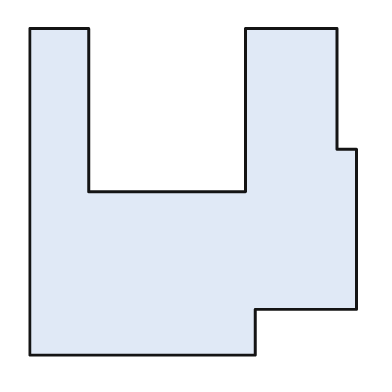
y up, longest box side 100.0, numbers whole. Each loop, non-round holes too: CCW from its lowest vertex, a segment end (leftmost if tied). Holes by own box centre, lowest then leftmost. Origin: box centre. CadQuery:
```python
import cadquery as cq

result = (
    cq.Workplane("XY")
    .moveTo(-50.0, -50.0)
    .lineTo(19.0, -50.0)
    .lineTo(19.0, -36.0)
    .lineTo(50.0, -36.0)
    .lineTo(50.0, 13.0)
    .lineTo(44.0, 13.0)
    .lineTo(44.0, 50.0)
    .lineTo(16.0, 50.0)
    .lineTo(16.0, 0.0)
    .lineTo(-32.0, 0.0)
    .lineTo(-32.0, 50.0)
    .lineTo(-50.0, 50.0)
    .close()
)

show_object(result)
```